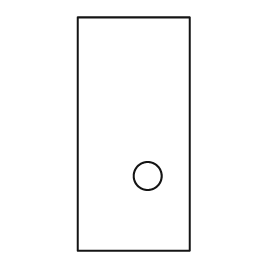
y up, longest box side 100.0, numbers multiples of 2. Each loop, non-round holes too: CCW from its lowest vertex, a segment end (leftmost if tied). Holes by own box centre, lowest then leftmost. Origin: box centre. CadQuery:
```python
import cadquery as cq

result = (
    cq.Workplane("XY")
    .moveTo(-24.0, -50.0)
    .lineTo(24.0, -50.0)
    .lineTo(24.0, 50.0)
    .lineTo(-24.0, 50.0)
    .close()
    .moveTo(6.0, -18.0)
    .circle(6.0)
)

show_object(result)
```